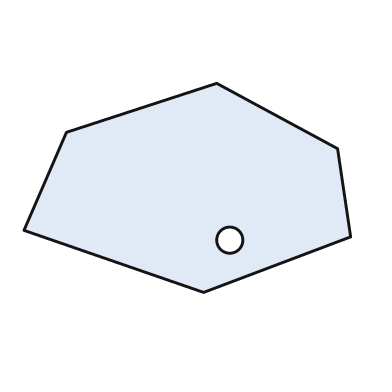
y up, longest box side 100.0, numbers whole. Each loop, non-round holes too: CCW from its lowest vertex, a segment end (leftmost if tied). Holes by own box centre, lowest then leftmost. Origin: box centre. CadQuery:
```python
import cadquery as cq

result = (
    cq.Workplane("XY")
    .moveTo(5.0, -32.0)
    .lineTo(50.0, -15.0)
    .lineTo(46.0, 12.0)
    .lineTo(9.0, 32.0)
    .lineTo(-37.0, 17.0)
    .lineTo(-50.0, -13.0)
    .close()
    .moveTo(13.0, -16.0)
    .circle(4.0)
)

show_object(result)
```